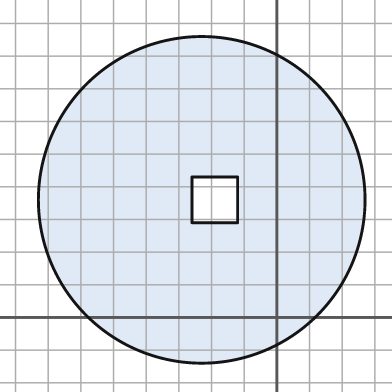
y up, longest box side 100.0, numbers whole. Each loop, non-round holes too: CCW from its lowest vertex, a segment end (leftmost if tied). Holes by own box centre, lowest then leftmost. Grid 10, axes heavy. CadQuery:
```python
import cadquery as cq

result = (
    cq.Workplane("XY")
    .moveTo(-23.0, 36.0)
    .circle(50.0)
    .moveTo(-26.0, 29.0)
    .lineTo(-12.0, 29.0)
    .lineTo(-12.0, 43.0)
    .lineTo(-26.0, 43.0)
    .close()
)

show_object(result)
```